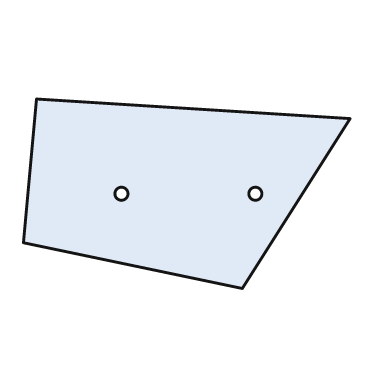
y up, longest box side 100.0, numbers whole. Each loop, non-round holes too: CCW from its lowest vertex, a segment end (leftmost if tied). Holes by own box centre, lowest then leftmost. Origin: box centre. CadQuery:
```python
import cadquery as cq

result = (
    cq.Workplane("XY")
    .moveTo(17.0, -29.0)
    .lineTo(50.0, 23.0)
    .lineTo(-46.0, 29.0)
    .lineTo(-50.0, -15.0)
    .close()
    .moveTo(-20.0, 0.0)
    .circle(2.0)
    .moveTo(21.0, 0.0)
    .circle(2.0)
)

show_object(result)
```